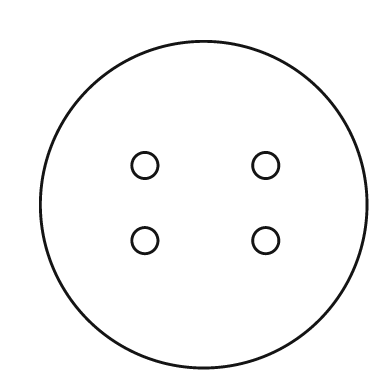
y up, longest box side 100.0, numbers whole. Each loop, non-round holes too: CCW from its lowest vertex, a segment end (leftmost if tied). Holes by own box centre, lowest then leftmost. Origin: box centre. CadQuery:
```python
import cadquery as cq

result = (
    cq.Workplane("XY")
    .moveTo(0.0, 0.0)
    .circle(50.0)
    .moveTo(-18.0, -11.0)
    .circle(4.0)
    .moveTo(19.0, -11.0)
    .circle(4.0)
    .moveTo(-18.0, 12.0)
    .circle(4.0)
    .moveTo(19.0, 12.0)
    .circle(4.0)
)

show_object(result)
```